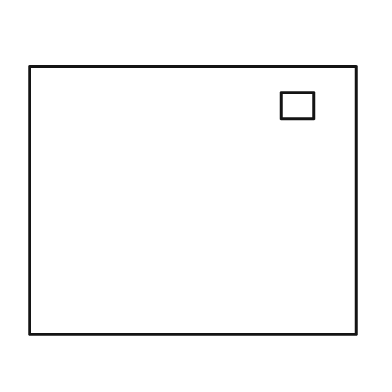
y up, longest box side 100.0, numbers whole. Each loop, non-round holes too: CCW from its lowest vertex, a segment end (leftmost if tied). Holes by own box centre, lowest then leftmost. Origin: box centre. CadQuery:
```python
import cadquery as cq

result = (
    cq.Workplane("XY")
    .moveTo(-50.0, -41.0)
    .lineTo(50.0, -41.0)
    .lineTo(50.0, 41.0)
    .lineTo(-50.0, 41.0)
    .close()
    .moveTo(27.0, 25.0)
    .lineTo(37.0, 25.0)
    .lineTo(37.0, 33.0)
    .lineTo(27.0, 33.0)
    .close()
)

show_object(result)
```